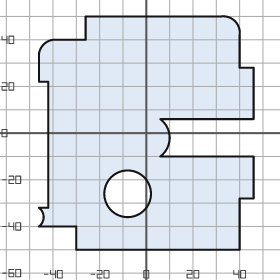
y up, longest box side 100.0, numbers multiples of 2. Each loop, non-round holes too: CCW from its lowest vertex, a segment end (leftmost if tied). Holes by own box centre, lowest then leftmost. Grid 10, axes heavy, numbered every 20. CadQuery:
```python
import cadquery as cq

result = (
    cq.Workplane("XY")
    .moveTo(-30.0, -50.0)
    .lineTo(40.0, -50.0)
    .lineTo(40.0, -28.0)
    .lineTo(46.0, -28.0)
    .lineTo(46.0, -10.0)
    .lineTo(6.0, -10.0)
    .threePointArc((10.0, -2.0), (6.0, 6.0))
    .lineTo(46.0, 6.0)
    .lineTo(46.0, 28.0)
    .lineTo(40.0, 28.0)
    .lineTo(40.0, 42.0)
    .threePointArc((38.0, 48.0), (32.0, 50.0))
    .lineTo(-26.0, 50.0)
    .lineTo(-26.0, 40.0)
    .lineTo(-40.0, 40.0)
    .threePointArc((-44.0, 38.0), (-46.0, 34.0))
    .lineTo(-46.0, 22.0)
    .lineTo(-42.0, 22.0)
    .lineTo(-42.0, -32.0)
    .lineTo(-46.0, -32.0)
    .threePointArc((-44.0, -36.0), (-46.0, -40.0))
    .lineTo(-30.0, -40.0)
    .close()
    .moveTo(-8.0, -26.0)
    .circle(10.0)
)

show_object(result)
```